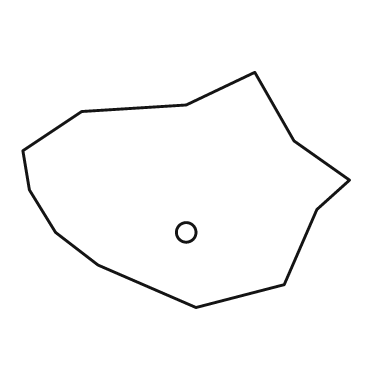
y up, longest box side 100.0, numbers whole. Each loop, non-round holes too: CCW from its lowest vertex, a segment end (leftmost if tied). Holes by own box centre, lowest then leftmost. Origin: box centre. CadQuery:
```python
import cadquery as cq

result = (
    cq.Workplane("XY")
    .moveTo(3.0, -36.0)
    .lineTo(30.0, -29.0)
    .lineTo(40.0, -6.0)
    .lineTo(50.0, 3.0)
    .lineTo(33.0, 15.0)
    .lineTo(21.0, 36.0)
    .lineTo(0.0, 26.0)
    .lineTo(-32.0, 24.0)
    .lineTo(-50.0, 12.0)
    .lineTo(-48.0, 0.0)
    .lineTo(-40.0, -13.0)
    .lineTo(-27.0, -23.0)
    .close()
    .moveTo(0.0, -13.0)
    .circle(3.0)
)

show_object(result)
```